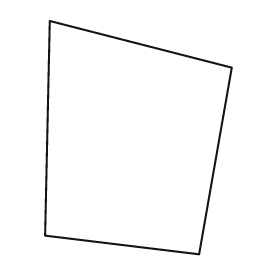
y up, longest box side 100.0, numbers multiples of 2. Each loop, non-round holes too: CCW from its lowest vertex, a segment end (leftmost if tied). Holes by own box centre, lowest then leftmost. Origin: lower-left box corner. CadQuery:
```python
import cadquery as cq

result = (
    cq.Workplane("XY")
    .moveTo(66.0, 0.0)
    .lineTo(80.0, 80.0)
    .lineTo(2.0, 100.0)
    .lineTo(0.0, 8.0)
    .close()
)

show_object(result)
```